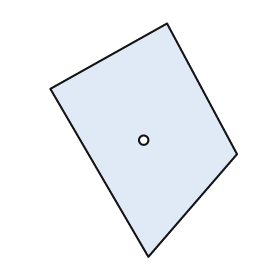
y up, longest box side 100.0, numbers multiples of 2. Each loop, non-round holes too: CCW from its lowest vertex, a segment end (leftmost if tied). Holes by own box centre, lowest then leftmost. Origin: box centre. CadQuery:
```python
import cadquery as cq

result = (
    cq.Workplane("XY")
    .moveTo(2.0, -50.0)
    .lineTo(40.0, -6.0)
    .lineTo(10.0, 50.0)
    .lineTo(-40.0, 22.0)
    .close()
    .moveTo(0.0, 0.0)
    .circle(2.0)
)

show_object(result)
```